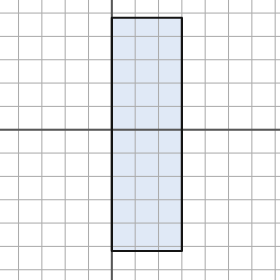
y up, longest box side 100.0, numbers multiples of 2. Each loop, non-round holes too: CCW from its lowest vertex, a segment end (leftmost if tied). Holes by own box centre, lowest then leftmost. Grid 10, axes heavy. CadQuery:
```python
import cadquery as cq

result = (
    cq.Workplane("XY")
    .moveTo(0.0, -52.0)
    .lineTo(30.0, -52.0)
    .lineTo(30.0, 48.0)
    .lineTo(0.0, 48.0)
    .close()
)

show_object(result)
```